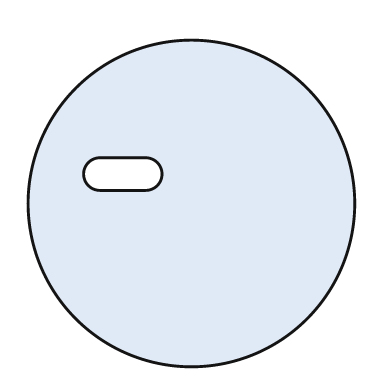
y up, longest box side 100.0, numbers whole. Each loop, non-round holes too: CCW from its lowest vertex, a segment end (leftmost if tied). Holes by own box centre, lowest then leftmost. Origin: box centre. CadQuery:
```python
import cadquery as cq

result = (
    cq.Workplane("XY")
    .moveTo(0.0, 0.0)
    .circle(50.0)
    .moveTo(-28.0, 4.0)
    .lineTo(-14.0, 4.0)
    .threePointArc((-9.0, 9.0), (-14.0, 14.0))
    .lineTo(-28.0, 14.0)
    .threePointArc((-33.0, 9.0), (-28.0, 4.0))
    .close()
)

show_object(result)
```